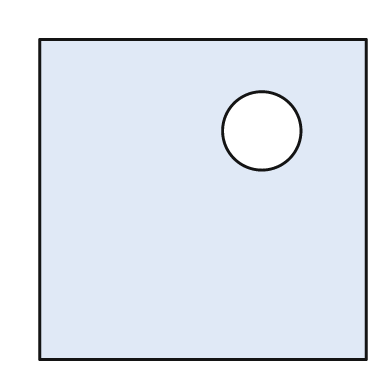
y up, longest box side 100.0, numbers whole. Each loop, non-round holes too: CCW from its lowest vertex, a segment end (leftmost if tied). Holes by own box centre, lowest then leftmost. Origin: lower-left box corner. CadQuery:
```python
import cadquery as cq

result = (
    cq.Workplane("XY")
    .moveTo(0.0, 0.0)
    .lineTo(100.0, 0.0)
    .lineTo(100.0, 98.0)
    .lineTo(0.0, 98.0)
    .close()
    .moveTo(68.0, 70.0)
    .circle(12.0)
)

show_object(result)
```